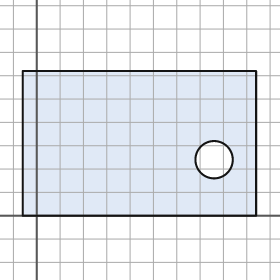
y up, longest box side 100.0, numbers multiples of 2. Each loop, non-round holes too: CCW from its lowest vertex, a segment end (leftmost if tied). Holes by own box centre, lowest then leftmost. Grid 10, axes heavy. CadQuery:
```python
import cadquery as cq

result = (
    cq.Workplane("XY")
    .moveTo(-6.0, 0.0)
    .lineTo(94.0, 0.0)
    .lineTo(94.0, 62.0)
    .lineTo(-6.0, 62.0)
    .close()
    .moveTo(76.0, 24.0)
    .circle(8.0)
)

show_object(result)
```